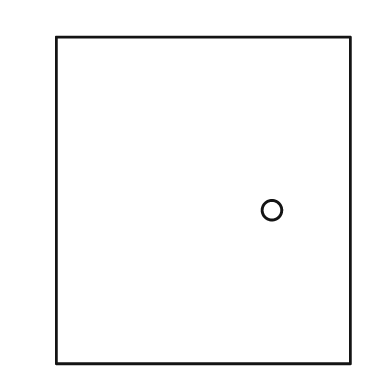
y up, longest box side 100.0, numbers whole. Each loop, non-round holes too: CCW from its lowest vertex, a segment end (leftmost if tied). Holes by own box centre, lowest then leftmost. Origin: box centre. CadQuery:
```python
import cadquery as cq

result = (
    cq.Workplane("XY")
    .moveTo(-45.0, -50.0)
    .lineTo(45.0, -50.0)
    .lineTo(45.0, 50.0)
    .lineTo(-45.0, 50.0)
    .close()
    .moveTo(21.0, -3.0)
    .circle(3.0)
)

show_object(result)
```